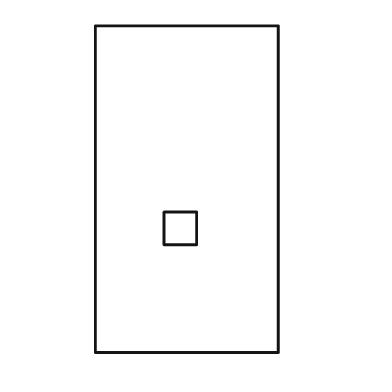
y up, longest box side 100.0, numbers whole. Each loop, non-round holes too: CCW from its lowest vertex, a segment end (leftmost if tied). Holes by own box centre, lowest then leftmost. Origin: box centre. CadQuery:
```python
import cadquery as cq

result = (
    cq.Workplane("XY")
    .moveTo(-28.0, -50.0)
    .lineTo(28.0, -50.0)
    .lineTo(28.0, 50.0)
    .lineTo(-28.0, 50.0)
    .close()
    .moveTo(-7.0, -17.0)
    .lineTo(3.0, -17.0)
    .lineTo(3.0, -7.0)
    .lineTo(-7.0, -7.0)
    .close()
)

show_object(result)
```